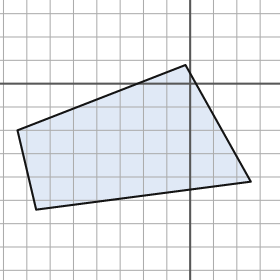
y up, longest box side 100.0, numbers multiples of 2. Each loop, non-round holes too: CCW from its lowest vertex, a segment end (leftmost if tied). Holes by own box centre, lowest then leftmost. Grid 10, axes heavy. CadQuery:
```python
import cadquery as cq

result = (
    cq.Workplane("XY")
    .moveTo(-66.0, -54.0)
    .lineTo(26.0, -42.0)
    .lineTo(-2.0, 8.0)
    .lineTo(-74.0, -20.0)
    .close()
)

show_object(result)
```